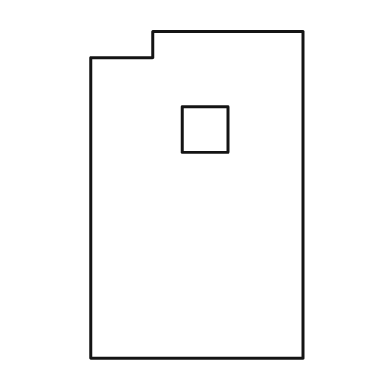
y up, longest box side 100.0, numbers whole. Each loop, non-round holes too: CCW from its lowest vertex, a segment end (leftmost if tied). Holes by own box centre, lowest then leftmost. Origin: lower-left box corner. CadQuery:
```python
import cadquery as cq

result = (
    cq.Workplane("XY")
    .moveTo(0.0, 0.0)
    .lineTo(65.0, 0.0)
    .lineTo(65.0, 100.0)
    .lineTo(19.0, 100.0)
    .lineTo(19.0, 92.0)
    .lineTo(0.0, 92.0)
    .close()
    .moveTo(28.0, 63.0)
    .lineTo(42.0, 63.0)
    .lineTo(42.0, 77.0)
    .lineTo(28.0, 77.0)
    .close()
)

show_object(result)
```